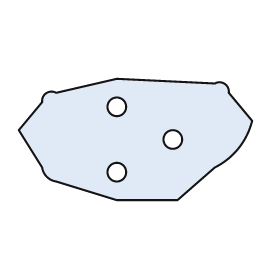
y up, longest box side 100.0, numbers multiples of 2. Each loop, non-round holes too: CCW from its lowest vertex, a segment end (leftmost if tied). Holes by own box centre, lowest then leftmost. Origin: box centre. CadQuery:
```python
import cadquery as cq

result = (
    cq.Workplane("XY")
    .moveTo(-8.0, -26.0)
    .lineTo(18.0, -26.0)
    .lineTo(34.0, -12.0)
    .threePointArc((44.0, -4.0), (50.0, 8.0))
    .lineTo(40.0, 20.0)
    .threePointArc((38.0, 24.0), (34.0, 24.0))
    .lineTo(-8.0, 26.0)
    .lineTo(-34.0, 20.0)
    .threePointArc((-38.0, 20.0), (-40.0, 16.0))
    .lineTo(-50.0, 4.0)
    .lineTo(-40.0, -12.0)
    .threePointArc((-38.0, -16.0), (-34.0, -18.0))
    .close()
    .moveTo(-8.0, -14.0)
    .circle(4.0)
    .moveTo(16.0, 0.0)
    .circle(4.0)
    .moveTo(-8.0, 14.0)
    .circle(4.0)
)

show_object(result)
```